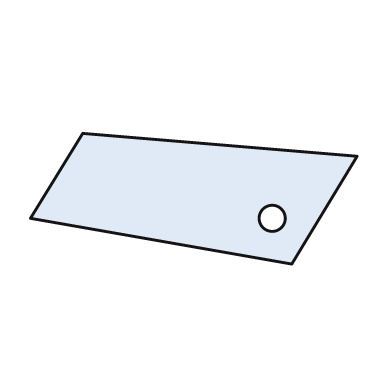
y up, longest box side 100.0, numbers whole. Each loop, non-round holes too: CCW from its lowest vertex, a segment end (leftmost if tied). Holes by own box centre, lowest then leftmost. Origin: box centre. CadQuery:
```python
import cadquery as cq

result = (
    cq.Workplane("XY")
    .moveTo(30.0, -20.0)
    .lineTo(50.0, 13.0)
    .lineTo(-34.0, 20.0)
    .lineTo(-50.0, -6.0)
    .close()
    .moveTo(24.0, -6.0)
    .circle(4.0)
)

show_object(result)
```